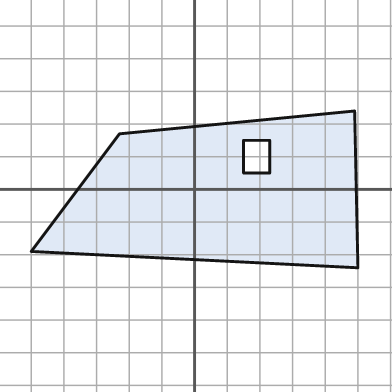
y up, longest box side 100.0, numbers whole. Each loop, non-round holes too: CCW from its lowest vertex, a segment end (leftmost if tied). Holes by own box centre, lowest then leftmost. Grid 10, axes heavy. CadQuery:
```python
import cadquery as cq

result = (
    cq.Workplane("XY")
    .moveTo(50.0, -24.0)
    .lineTo(49.0, 24.0)
    .lineTo(-23.0, 17.0)
    .lineTo(-50.0, -19.0)
    .close()
    .moveTo(15.0, 5.0)
    .lineTo(23.0, 5.0)
    .lineTo(23.0, 15.0)
    .lineTo(15.0, 15.0)
    .close()
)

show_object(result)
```